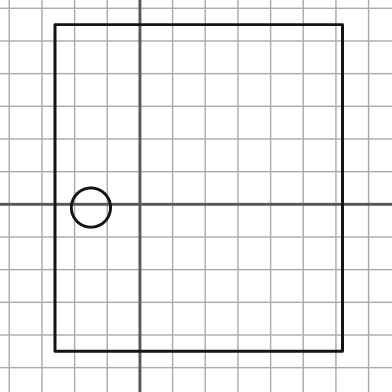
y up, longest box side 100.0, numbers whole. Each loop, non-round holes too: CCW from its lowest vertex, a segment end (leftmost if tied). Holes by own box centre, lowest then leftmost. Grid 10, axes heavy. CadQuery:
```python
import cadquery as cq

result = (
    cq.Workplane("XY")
    .moveTo(-26.0, -45.0)
    .lineTo(62.0, -45.0)
    .lineTo(62.0, 55.0)
    .lineTo(-26.0, 55.0)
    .close()
    .moveTo(-15.0, -1.0)
    .circle(6.0)
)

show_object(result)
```